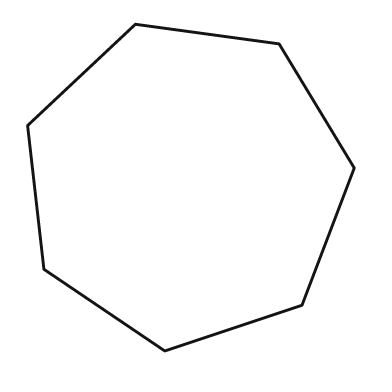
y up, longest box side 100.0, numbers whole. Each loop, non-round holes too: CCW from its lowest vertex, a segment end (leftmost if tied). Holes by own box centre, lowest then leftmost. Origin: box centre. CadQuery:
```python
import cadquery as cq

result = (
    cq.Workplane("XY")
    .moveTo(-8.0, -50.0)
    .lineTo(34.0, -36.0)
    .lineTo(50.0, 6.0)
    .lineTo(27.0, 44.0)
    .lineTo(-17.0, 50.0)
    .lineTo(-50.0, 19.0)
    .lineTo(-45.0, -25.0)
    .close()
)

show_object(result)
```